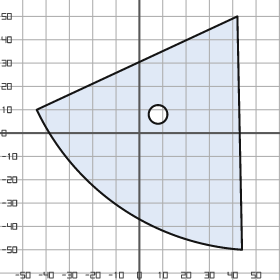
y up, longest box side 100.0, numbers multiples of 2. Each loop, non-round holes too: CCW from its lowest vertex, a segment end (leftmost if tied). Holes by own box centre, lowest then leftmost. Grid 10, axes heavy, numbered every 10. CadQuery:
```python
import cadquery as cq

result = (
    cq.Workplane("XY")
    .moveTo(44.0, -50.0)
    .lineTo(42.0, 50.0)
    .lineTo(-44.0, 10.0)
    .threePointArc((-8.0, -32.0), (44.0, -50.0))
    .close()
    .moveTo(8.0, 8.0)
    .circle(4.0)
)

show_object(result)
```